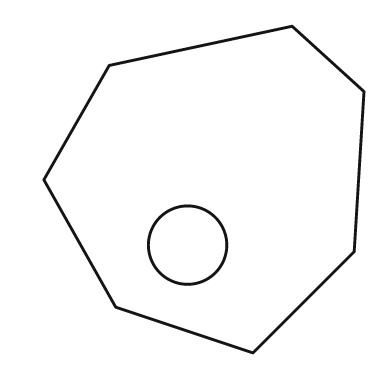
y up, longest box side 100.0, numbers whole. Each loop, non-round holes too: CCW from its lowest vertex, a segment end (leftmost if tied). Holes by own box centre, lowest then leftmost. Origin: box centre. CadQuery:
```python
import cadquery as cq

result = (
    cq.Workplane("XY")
    .moveTo(15.0, -50.0)
    .lineTo(46.0, -19.0)
    .lineTo(49.0, 30.0)
    .lineTo(27.0, 50.0)
    .lineTo(-29.0, 38.0)
    .lineTo(-49.0, 3.0)
    .lineTo(-27.0, -36.0)
    .close()
    .moveTo(-5.0, -17.0)
    .circle(12.0)
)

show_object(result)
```